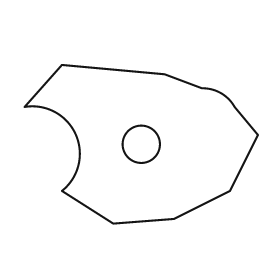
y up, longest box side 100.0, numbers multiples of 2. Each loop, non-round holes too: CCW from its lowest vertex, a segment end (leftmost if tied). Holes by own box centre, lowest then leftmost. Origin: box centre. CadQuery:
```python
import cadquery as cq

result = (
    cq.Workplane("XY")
    .moveTo(-12.0, -34.0)
    .lineTo(14.0, -32.0)
    .lineTo(38.0, -20.0)
    .lineTo(50.0, 4.0)
    .lineTo(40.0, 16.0)
    .threePointArc((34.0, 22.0), (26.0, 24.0))
    .lineTo(10.0, 30.0)
    .lineTo(-34.0, 34.0)
    .lineTo(-50.0, 16.0)
    .threePointArc((-28.0, 4.0), (-34.0, -20.0))
    .close()
    .moveTo(0.0, 0.0)
    .circle(8.0)
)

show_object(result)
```